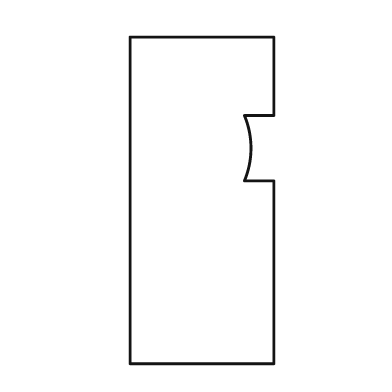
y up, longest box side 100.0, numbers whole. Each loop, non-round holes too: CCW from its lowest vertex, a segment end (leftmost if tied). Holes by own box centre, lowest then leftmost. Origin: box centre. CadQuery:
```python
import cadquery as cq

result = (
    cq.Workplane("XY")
    .moveTo(-22.0, -50.0)
    .lineTo(22.0, -50.0)
    .lineTo(22.0, 6.0)
    .lineTo(13.0, 6.0)
    .threePointArc((15.0, 16.0), (13.0, 26.0))
    .lineTo(22.0, 26.0)
    .lineTo(22.0, 50.0)
    .lineTo(-22.0, 50.0)
    .close()
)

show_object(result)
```